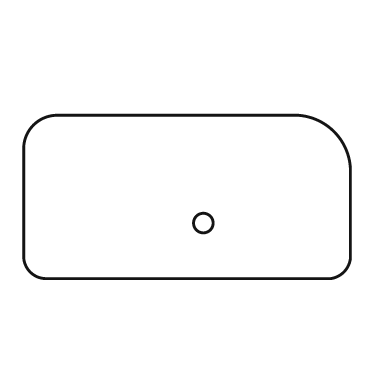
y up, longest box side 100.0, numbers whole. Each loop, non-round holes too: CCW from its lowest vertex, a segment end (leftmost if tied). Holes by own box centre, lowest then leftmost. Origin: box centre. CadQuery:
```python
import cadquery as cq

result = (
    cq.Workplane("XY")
    .moveTo(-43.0, -25.0)
    .lineTo(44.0, -25.0)
    .threePointArc((48.0, -23.0), (50.0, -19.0))
    .lineTo(50.0, 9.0)
    .threePointArc((45.0, 20.0), (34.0, 25.0))
    .lineTo(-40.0, 25.0)
    .threePointArc((-47.0, 22.0), (-50.0, 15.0))
    .lineTo(-50.0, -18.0)
    .threePointArc((-48.0, -23.0), (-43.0, -25.0))
    .close()
    .moveTo(5.0, -8.0)
    .circle(3.0)
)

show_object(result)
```